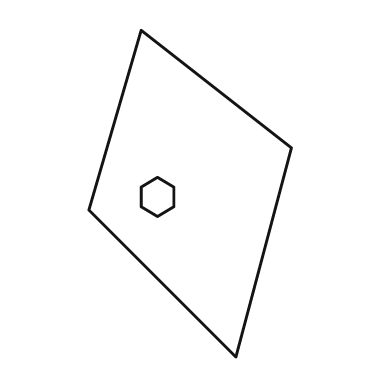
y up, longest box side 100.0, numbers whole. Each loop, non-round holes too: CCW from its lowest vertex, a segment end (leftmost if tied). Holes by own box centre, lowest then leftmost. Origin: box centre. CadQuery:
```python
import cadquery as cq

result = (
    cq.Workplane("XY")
    .moveTo(14.0, -50.0)
    .lineTo(31.0, 14.0)
    .lineTo(-15.0, 50.0)
    .lineTo(-31.0, -5.0)
    .close()
    .moveTo(-10.0, -7.0)
    .lineTo(-5.0, -4.0)
    .lineTo(-5.0, 2.0)
    .lineTo(-10.0, 5.0)
    .lineTo(-15.0, 2.0)
    .lineTo(-15.0, -4.0)
    .close()
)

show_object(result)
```